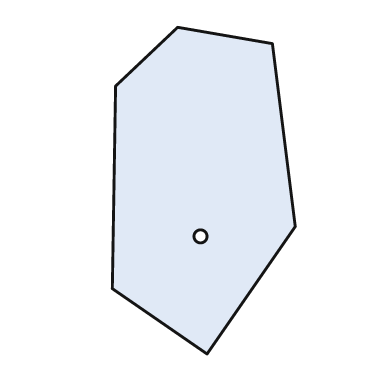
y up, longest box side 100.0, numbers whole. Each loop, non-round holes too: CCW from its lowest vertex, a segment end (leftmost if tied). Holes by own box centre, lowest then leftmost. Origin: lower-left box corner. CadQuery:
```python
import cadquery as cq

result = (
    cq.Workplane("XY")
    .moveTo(29.0, 0.0)
    .lineTo(56.0, 39.0)
    .lineTo(49.0, 95.0)
    .lineTo(20.0, 100.0)
    .lineTo(1.0, 82.0)
    .lineTo(0.0, 20.0)
    .close()
    .moveTo(27.0, 36.0)
    .circle(2.0)
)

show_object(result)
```